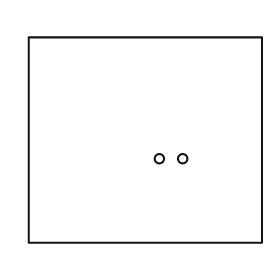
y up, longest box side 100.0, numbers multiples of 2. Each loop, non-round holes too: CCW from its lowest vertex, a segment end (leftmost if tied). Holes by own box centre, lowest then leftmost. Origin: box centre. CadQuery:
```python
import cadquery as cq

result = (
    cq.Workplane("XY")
    .moveTo(-50.0, -44.0)
    .lineTo(50.0, -44.0)
    .lineTo(50.0, 44.0)
    .lineTo(-50.0, 44.0)
    .close()
    .moveTo(6.0, -8.0)
    .circle(2.0)
    .moveTo(16.0, -8.0)
    .circle(2.0)
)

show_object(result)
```